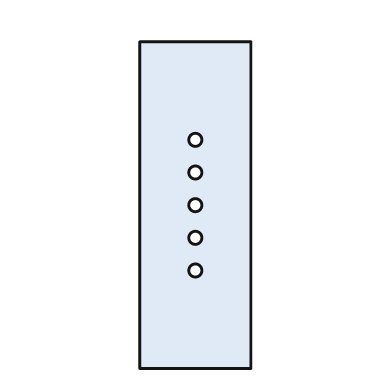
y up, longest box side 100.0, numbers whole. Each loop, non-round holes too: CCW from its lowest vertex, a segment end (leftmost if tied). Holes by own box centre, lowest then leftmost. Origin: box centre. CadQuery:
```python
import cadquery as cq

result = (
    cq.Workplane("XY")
    .moveTo(-17.0, -50.0)
    .lineTo(17.0, -50.0)
    .lineTo(17.0, 50.0)
    .lineTo(-17.0, 50.0)
    .close()
    .moveTo(0.0, -20.0)
    .circle(2.0)
    .moveTo(0.0, -10.0)
    .circle(2.0)
    .moveTo(0.0, 0.0)
    .circle(2.0)
    .moveTo(0.0, 10.0)
    .circle(2.0)
    .moveTo(0.0, 20.0)
    .circle(2.0)
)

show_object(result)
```